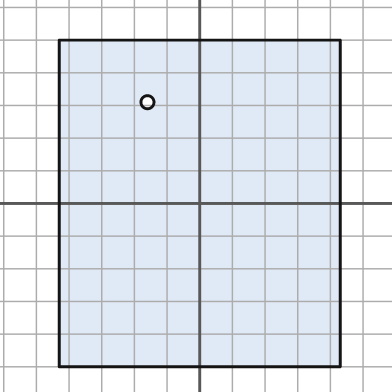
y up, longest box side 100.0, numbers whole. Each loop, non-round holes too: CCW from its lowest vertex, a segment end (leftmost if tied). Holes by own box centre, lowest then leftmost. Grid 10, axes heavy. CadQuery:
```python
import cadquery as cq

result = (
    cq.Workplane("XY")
    .moveTo(-43.0, -50.0)
    .lineTo(43.0, -50.0)
    .lineTo(43.0, 50.0)
    .lineTo(-43.0, 50.0)
    .close()
    .moveTo(-16.0, 31.0)
    .circle(2.0)
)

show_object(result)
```